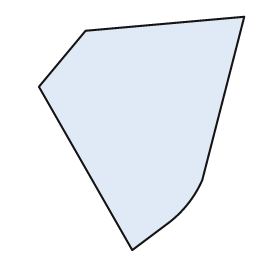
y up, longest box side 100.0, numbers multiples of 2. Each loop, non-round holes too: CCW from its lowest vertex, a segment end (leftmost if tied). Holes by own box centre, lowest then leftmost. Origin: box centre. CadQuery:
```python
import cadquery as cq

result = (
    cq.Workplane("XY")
    .moveTo(-4.0, -50.0)
    .lineTo(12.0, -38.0)
    .threePointArc((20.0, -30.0), (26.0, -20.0))
    .lineTo(44.0, 50.0)
    .lineTo(-24.0, 44.0)
    .lineTo(-44.0, 20.0)
    .close()
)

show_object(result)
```